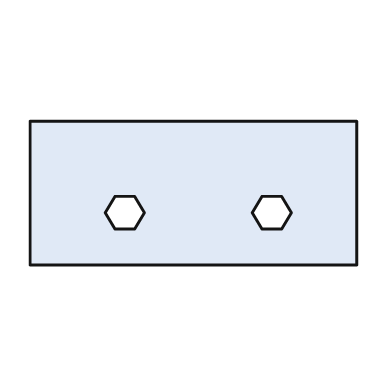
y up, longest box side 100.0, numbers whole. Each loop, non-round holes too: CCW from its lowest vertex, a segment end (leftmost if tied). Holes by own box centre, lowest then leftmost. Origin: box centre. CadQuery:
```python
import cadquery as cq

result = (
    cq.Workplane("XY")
    .moveTo(-50.0, -22.0)
    .lineTo(50.0, -22.0)
    .lineTo(50.0, 22.0)
    .lineTo(-50.0, 22.0)
    .close()
    .moveTo(-24.0, -11.0)
    .lineTo(-18.0, -11.0)
    .lineTo(-15.0, -6.0)
    .lineTo(-18.0, -1.0)
    .lineTo(-24.0, -1.0)
    .lineTo(-27.0, -6.0)
    .close()
    .moveTo(21.0, -11.0)
    .lineTo(27.0, -11.0)
    .lineTo(30.0, -6.0)
    .lineTo(27.0, -1.0)
    .lineTo(21.0, -1.0)
    .lineTo(18.0, -6.0)
    .close()
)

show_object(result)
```